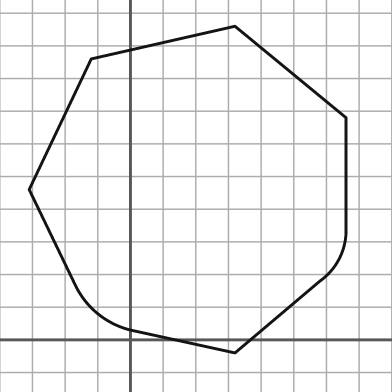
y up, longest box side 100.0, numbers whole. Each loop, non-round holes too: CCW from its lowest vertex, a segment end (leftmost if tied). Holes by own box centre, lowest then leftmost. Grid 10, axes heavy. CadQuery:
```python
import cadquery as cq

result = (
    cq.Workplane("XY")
    .moveTo(32.0, -4.0)
    .lineTo(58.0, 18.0)
    .threePointArc((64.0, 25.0), (66.0, 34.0))
    .lineTo(66.0, 68.0)
    .lineTo(32.0, 96.0)
    .lineTo(-12.0, 86.0)
    .lineTo(-31.0, 46.0)
    .lineTo(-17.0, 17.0)
    .threePointArc((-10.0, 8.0), (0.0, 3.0))
    .close()
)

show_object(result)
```